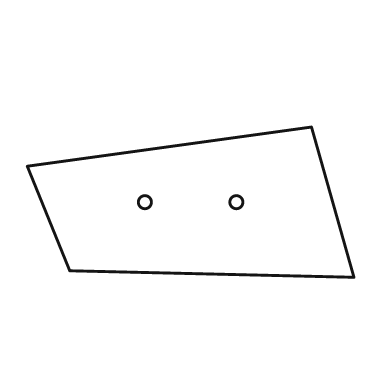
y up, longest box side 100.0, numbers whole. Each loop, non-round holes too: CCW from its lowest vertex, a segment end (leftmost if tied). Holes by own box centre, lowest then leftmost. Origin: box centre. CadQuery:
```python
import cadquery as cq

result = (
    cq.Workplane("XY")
    .moveTo(50.0, -23.0)
    .lineTo(37.0, 23.0)
    .lineTo(-50.0, 11.0)
    .lineTo(-37.0, -21.0)
    .close()
    .moveTo(-14.0, 0.0)
    .circle(2.0)
    .moveTo(14.0, 0.0)
    .circle(2.0)
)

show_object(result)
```